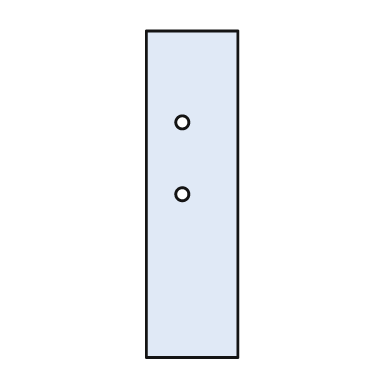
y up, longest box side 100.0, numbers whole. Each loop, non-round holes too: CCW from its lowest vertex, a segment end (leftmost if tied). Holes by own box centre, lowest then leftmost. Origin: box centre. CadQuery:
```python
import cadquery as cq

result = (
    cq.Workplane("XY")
    .moveTo(-14.0, -50.0)
    .lineTo(14.0, -50.0)
    .lineTo(14.0, 50.0)
    .lineTo(-14.0, 50.0)
    .close()
    .moveTo(-3.0, 0.0)
    .circle(2.0)
    .moveTo(-3.0, 22.0)
    .circle(2.0)
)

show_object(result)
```